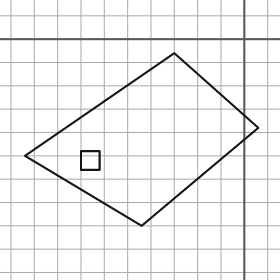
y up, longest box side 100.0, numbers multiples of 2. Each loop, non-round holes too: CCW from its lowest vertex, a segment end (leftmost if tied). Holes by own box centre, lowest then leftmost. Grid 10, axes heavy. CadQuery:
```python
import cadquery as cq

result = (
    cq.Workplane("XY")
    .moveTo(-44.0, -80.0)
    .lineTo(6.0, -38.0)
    .lineTo(-30.0, -6.0)
    .lineTo(-94.0, -50.0)
    .close()
    .moveTo(-70.0, -56.0)
    .lineTo(-62.0, -56.0)
    .lineTo(-62.0, -48.0)
    .lineTo(-70.0, -48.0)
    .close()
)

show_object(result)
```